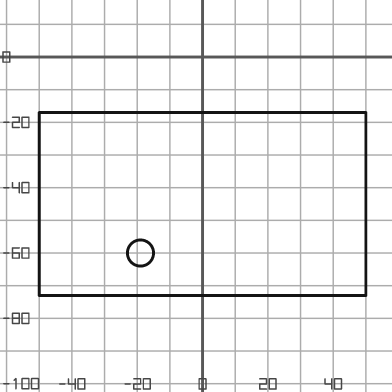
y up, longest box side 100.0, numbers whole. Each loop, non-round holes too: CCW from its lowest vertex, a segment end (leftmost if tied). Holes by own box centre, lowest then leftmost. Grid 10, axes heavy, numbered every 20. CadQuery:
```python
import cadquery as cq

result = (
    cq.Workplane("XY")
    .moveTo(-50.0, -73.0)
    .lineTo(50.0, -73.0)
    .lineTo(50.0, -17.0)
    .lineTo(-50.0, -17.0)
    .close()
    .moveTo(-19.0, -60.0)
    .circle(4.0)
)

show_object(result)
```